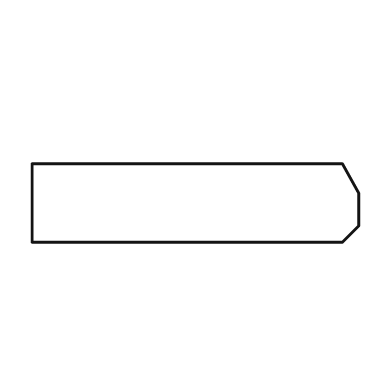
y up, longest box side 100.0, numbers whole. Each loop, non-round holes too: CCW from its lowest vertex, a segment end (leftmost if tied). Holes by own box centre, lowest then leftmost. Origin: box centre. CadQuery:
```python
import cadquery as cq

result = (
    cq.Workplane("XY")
    .moveTo(-50.0, -12.0)
    .lineTo(45.0, -12.0)
    .lineTo(50.0, -7.0)
    .lineTo(50.0, 3.0)
    .lineTo(45.0, 12.0)
    .lineTo(-50.0, 12.0)
    .close()
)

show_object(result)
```